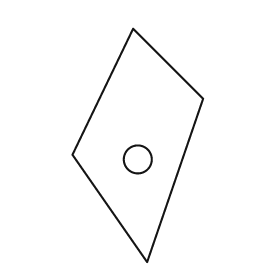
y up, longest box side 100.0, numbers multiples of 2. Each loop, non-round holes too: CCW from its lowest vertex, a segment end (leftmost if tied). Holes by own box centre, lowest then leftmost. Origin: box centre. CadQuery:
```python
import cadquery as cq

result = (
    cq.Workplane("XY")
    .moveTo(4.0, -50.0)
    .lineTo(28.0, 20.0)
    .lineTo(-2.0, 50.0)
    .lineTo(-28.0, -4.0)
    .close()
    .moveTo(0.0, -6.0)
    .circle(6.0)
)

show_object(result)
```